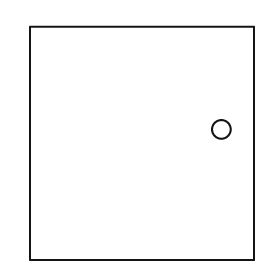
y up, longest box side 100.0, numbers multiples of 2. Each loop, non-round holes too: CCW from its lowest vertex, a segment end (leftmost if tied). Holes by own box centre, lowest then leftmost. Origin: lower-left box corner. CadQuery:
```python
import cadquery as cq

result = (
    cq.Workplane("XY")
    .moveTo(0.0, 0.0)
    .lineTo(96.0, 0.0)
    .lineTo(96.0, 100.0)
    .lineTo(0.0, 100.0)
    .close()
    .moveTo(82.0, 56.0)
    .circle(4.0)
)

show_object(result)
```